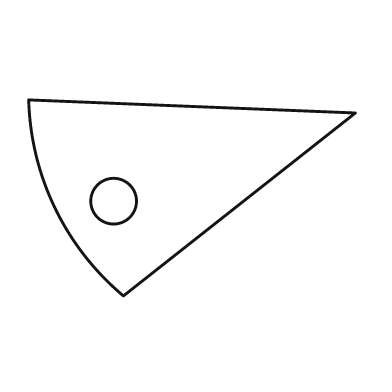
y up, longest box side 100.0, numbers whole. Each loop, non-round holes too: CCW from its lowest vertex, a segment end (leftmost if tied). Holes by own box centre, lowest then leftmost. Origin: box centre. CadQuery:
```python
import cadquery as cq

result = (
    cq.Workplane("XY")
    .moveTo(-21.0, -30.0)
    .lineTo(50.0, 26.0)
    .lineTo(-50.0, 30.0)
    .threePointArc((-42.0, -3.0), (-21.0, -30.0))
    .close()
    .moveTo(-24.0, -1.0)
    .circle(7.0)
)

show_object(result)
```